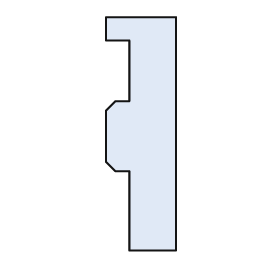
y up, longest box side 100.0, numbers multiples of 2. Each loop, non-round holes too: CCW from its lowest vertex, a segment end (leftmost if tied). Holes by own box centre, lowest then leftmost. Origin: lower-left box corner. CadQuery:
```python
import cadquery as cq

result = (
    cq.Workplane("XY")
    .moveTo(10.0, 0.0)
    .lineTo(30.0, 0.0)
    .lineTo(30.0, 100.0)
    .lineTo(0.0, 100.0)
    .lineTo(0.0, 90.0)
    .lineTo(10.0, 90.0)
    .lineTo(10.0, 64.0)
    .lineTo(4.0, 64.0)
    .lineTo(0.0, 60.0)
    .lineTo(0.0, 38.0)
    .lineTo(4.0, 34.0)
    .lineTo(10.0, 34.0)
    .close()
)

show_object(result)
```